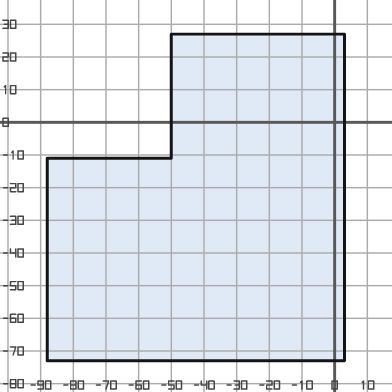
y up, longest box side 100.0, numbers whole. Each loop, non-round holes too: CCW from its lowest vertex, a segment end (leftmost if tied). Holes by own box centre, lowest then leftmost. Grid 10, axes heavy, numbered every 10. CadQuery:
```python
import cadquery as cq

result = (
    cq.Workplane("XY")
    .moveTo(-88.0, -73.0)
    .lineTo(3.0, -73.0)
    .lineTo(3.0, 27.0)
    .lineTo(-50.0, 27.0)
    .lineTo(-50.0, -11.0)
    .lineTo(-88.0, -11.0)
    .close()
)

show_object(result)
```